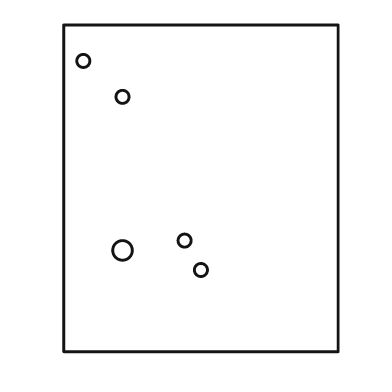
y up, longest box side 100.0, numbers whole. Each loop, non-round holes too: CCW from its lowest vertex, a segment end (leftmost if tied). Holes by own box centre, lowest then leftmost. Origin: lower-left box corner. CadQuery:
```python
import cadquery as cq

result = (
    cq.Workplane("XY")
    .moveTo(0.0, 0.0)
    .lineTo(84.0, 0.0)
    .lineTo(84.0, 100.0)
    .lineTo(0.0, 100.0)
    .close()
    .moveTo(42.0, 25.0)
    .circle(2.0)
    .moveTo(18.0, 31.0)
    .circle(3.0)
    .moveTo(37.0, 34.0)
    .circle(2.0)
    .moveTo(18.0, 78.0)
    .circle(2.0)
    .moveTo(6.0, 89.0)
    .circle(2.0)
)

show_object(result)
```